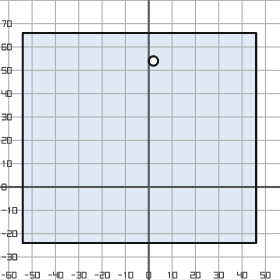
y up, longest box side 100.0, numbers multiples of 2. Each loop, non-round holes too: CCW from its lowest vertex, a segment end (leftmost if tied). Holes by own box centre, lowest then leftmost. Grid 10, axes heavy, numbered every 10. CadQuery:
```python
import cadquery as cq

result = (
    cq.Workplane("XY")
    .moveTo(-54.0, -24.0)
    .lineTo(46.0, -24.0)
    .lineTo(46.0, 66.0)
    .lineTo(-54.0, 66.0)
    .close()
    .moveTo(2.0, 54.0)
    .circle(2.0)
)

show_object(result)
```